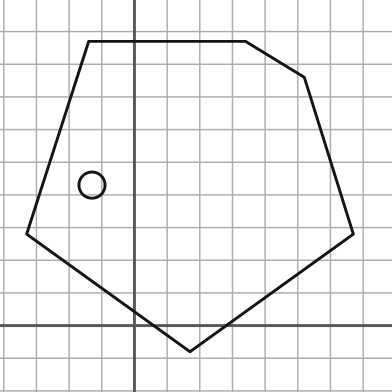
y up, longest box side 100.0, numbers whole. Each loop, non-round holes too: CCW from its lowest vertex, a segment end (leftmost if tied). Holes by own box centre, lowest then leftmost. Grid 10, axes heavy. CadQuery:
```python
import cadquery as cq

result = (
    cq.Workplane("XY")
    .moveTo(17.0, -8.0)
    .lineTo(67.0, 28.0)
    .lineTo(52.0, 76.0)
    .lineTo(34.0, 87.0)
    .lineTo(-14.0, 87.0)
    .lineTo(-33.0, 28.0)
    .close()
    .moveTo(-13.0, 43.0)
    .circle(4.0)
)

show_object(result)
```